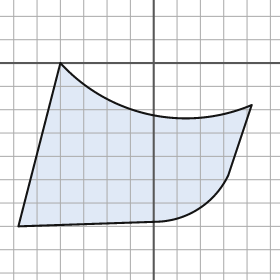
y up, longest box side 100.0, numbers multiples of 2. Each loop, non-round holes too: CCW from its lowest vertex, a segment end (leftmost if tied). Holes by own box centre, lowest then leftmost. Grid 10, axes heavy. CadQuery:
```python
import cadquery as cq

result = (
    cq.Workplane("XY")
    .moveTo(-58.0, -70.0)
    .lineTo(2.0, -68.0)
    .threePointArc((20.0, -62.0), (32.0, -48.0))
    .lineTo(42.0, -18.0)
    .threePointArc((-2.0, -22.0), (-40.0, 0.0))
    .close()
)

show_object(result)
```